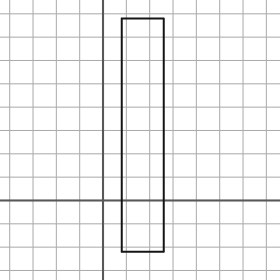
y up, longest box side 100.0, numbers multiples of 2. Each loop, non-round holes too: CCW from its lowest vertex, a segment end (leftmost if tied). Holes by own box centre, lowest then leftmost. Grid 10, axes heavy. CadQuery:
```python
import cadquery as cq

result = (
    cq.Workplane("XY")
    .moveTo(8.0, -22.0)
    .lineTo(26.0, -22.0)
    .lineTo(26.0, 78.0)
    .lineTo(8.0, 78.0)
    .close()
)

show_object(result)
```